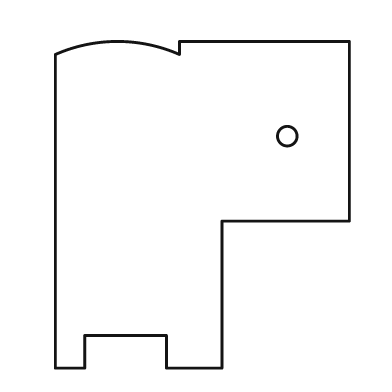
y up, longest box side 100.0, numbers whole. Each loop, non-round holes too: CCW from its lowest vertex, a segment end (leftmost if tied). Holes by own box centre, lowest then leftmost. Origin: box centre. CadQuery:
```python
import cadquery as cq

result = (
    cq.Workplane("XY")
    .moveTo(-45.0, -50.0)
    .lineTo(-36.0, -50.0)
    .lineTo(-36.0, -40.0)
    .lineTo(-11.0, -40.0)
    .lineTo(-11.0, -50.0)
    .lineTo(6.0, -50.0)
    .lineTo(6.0, -5.0)
    .lineTo(45.0, -5.0)
    .lineTo(45.0, 50.0)
    .lineTo(-7.0, 50.0)
    .lineTo(-7.0, 46.0)
    .threePointArc((-26.0, 50.0), (-45.0, 46.0))
    .close()
    .moveTo(26.0, 21.0)
    .circle(3.0)
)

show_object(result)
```